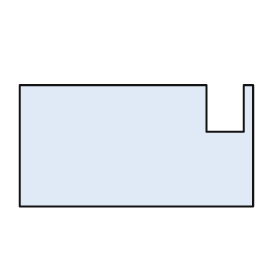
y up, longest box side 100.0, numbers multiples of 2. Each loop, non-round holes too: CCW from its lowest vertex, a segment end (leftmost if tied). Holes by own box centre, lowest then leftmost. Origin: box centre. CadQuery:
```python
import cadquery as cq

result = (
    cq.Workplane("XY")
    .moveTo(-50.0, -26.0)
    .lineTo(50.0, -26.0)
    .lineTo(50.0, 26.0)
    .lineTo(46.0, 26.0)
    .lineTo(46.0, 6.0)
    .lineTo(30.0, 6.0)
    .lineTo(30.0, 26.0)
    .lineTo(-50.0, 26.0)
    .close()
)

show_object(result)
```